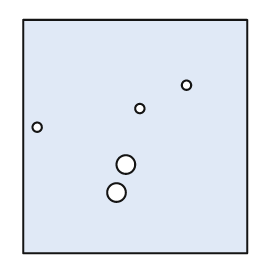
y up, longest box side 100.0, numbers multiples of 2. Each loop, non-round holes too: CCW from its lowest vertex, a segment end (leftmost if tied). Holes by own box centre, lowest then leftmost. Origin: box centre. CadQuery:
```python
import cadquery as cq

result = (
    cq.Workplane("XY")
    .moveTo(-48.0, -50.0)
    .lineTo(48.0, -50.0)
    .lineTo(48.0, 50.0)
    .lineTo(-48.0, 50.0)
    .close()
    .moveTo(-8.0, -24.0)
    .circle(4.0)
    .moveTo(-4.0, -12.0)
    .circle(4.0)
    .moveTo(-42.0, 4.0)
    .circle(2.0)
    .moveTo(2.0, 12.0)
    .circle(2.0)
    .moveTo(22.0, 22.0)
    .circle(2.0)
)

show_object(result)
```